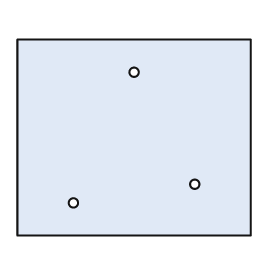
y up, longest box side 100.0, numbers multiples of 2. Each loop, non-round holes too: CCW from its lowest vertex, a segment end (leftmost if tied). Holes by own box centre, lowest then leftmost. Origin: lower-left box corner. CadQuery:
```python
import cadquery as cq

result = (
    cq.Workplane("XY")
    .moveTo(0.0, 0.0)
    .lineTo(100.0, 0.0)
    .lineTo(100.0, 84.0)
    .lineTo(0.0, 84.0)
    .close()
    .moveTo(24.0, 14.0)
    .circle(2.0)
    .moveTo(76.0, 22.0)
    .circle(2.0)
    .moveTo(50.0, 70.0)
    .circle(2.0)
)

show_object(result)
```